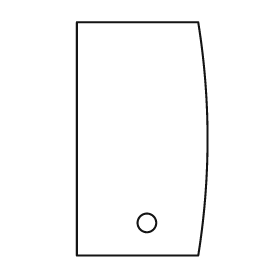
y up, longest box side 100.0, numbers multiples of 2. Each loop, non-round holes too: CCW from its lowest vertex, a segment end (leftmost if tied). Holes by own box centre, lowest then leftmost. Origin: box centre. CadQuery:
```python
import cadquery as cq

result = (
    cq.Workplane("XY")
    .moveTo(-28.0, -50.0)
    .lineTo(24.0, -50.0)
    .threePointArc((28.0, 0.0), (24.0, 50.0))
    .lineTo(-28.0, 50.0)
    .close()
    .moveTo(2.0, -36.0)
    .circle(4.0)
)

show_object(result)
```